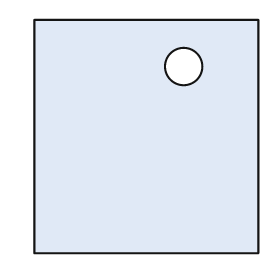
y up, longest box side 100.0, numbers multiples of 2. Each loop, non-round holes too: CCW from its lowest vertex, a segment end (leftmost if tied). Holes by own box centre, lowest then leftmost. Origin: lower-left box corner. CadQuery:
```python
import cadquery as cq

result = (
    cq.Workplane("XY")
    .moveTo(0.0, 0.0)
    .lineTo(96.0, 0.0)
    .lineTo(96.0, 100.0)
    .lineTo(0.0, 100.0)
    .close()
    .moveTo(64.0, 80.0)
    .circle(8.0)
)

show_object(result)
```